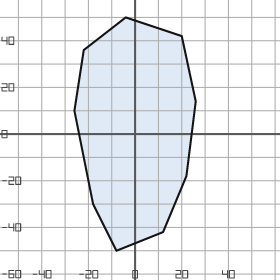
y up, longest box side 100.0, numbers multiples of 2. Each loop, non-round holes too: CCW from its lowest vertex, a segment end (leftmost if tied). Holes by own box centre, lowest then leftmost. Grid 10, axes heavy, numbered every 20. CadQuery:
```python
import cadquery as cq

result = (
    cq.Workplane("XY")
    .moveTo(-8.0, -50.0)
    .lineTo(12.0, -42.0)
    .lineTo(22.0, -18.0)
    .lineTo(26.0, 14.0)
    .lineTo(20.0, 42.0)
    .lineTo(-4.0, 50.0)
    .lineTo(-22.0, 36.0)
    .lineTo(-26.0, 10.0)
    .lineTo(-18.0, -30.0)
    .close()
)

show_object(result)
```